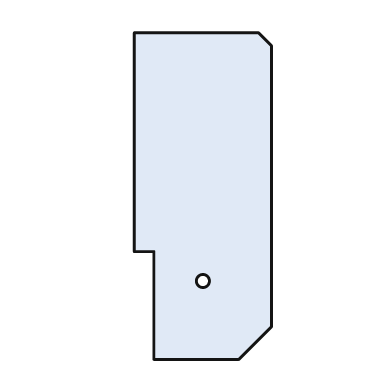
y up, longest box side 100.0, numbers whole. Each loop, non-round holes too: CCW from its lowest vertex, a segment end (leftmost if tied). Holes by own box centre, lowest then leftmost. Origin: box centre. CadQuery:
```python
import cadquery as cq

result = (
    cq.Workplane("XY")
    .moveTo(-15.0, -50.0)
    .lineTo(11.0, -50.0)
    .lineTo(21.0, -40.0)
    .lineTo(21.0, 46.0)
    .lineTo(17.0, 50.0)
    .lineTo(-21.0, 50.0)
    .lineTo(-21.0, -17.0)
    .lineTo(-15.0, -17.0)
    .close()
    .moveTo(0.0, -26.0)
    .circle(2.0)
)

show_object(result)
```